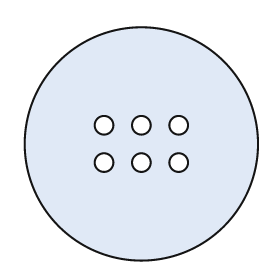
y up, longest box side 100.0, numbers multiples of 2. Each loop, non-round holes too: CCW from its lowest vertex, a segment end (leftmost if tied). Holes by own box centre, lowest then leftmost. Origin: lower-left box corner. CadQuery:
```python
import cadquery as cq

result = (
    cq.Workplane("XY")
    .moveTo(50.0, 50.0)
    .circle(50.0)
    .moveTo(34.0, 42.0)
    .circle(4.0)
    .moveTo(50.0, 42.0)
    .circle(4.0)
    .moveTo(66.0, 42.0)
    .circle(4.0)
    .moveTo(34.0, 58.0)
    .circle(4.0)
    .moveTo(50.0, 58.0)
    .circle(4.0)
    .moveTo(66.0, 58.0)
    .circle(4.0)
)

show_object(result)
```